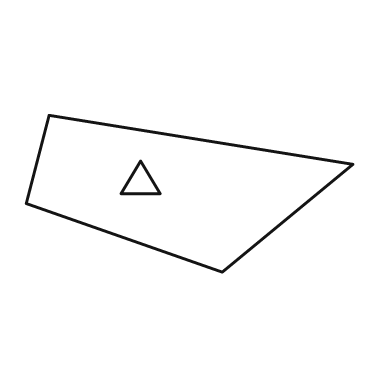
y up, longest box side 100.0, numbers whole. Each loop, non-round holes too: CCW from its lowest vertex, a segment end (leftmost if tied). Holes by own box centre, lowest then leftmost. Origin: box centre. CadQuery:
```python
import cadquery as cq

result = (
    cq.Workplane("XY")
    .moveTo(10.0, -24.0)
    .lineTo(50.0, 9.0)
    .lineTo(-43.0, 24.0)
    .lineTo(-50.0, -3.0)
    .close()
    .moveTo(-21.0, 0.0)
    .lineTo(-9.0, 0.0)
    .lineTo(-15.0, 10.0)
    .close()
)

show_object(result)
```